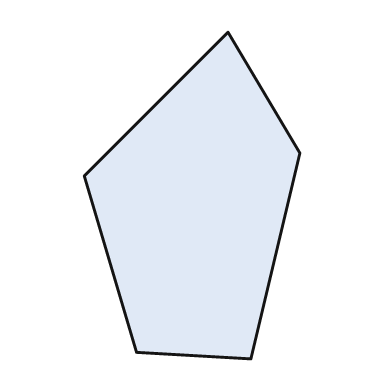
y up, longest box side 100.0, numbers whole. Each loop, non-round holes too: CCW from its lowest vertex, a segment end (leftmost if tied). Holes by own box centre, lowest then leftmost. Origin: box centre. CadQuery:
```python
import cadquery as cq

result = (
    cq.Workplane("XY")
    .moveTo(18.0, -50.0)
    .lineTo(33.0, 13.0)
    .lineTo(11.0, 50.0)
    .lineTo(-33.0, 6.0)
    .lineTo(-17.0, -48.0)
    .close()
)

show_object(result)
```